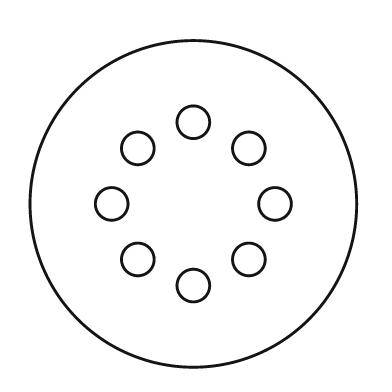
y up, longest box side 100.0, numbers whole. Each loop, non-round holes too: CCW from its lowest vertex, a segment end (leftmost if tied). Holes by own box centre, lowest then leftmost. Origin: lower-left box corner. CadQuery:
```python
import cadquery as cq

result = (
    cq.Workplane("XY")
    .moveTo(50.0, 50.0)
    .circle(50.0)
    .moveTo(50.0, 25.0)
    .circle(5.0)
    .moveTo(33.0, 33.0)
    .circle(5.0)
    .moveTo(67.0, 33.0)
    .circle(5.0)
    .moveTo(25.0, 50.0)
    .circle(5.0)
    .moveTo(75.0, 50.0)
    .circle(5.0)
    .moveTo(33.0, 67.0)
    .circle(5.0)
    .moveTo(67.0, 67.0)
    .circle(5.0)
    .moveTo(50.0, 75.0)
    .circle(5.0)
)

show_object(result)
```